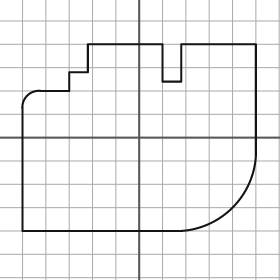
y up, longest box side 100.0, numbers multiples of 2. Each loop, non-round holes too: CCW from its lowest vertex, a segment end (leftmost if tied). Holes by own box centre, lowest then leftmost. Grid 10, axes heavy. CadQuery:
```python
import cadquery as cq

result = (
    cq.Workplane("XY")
    .moveTo(-50.0, -40.0)
    .lineTo(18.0, -40.0)
    .threePointArc((40.0, -30.0), (50.0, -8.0))
    .lineTo(50.0, 40.0)
    .lineTo(18.0, 40.0)
    .lineTo(18.0, 24.0)
    .lineTo(10.0, 24.0)
    .lineTo(10.0, 40.0)
    .lineTo(-22.0, 40.0)
    .lineTo(-22.0, 28.0)
    .lineTo(-30.0, 28.0)
    .lineTo(-30.0, 20.0)
    .lineTo(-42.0, 20.0)
    .threePointArc((-48.0, 18.0), (-50.0, 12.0))
    .close()
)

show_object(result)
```